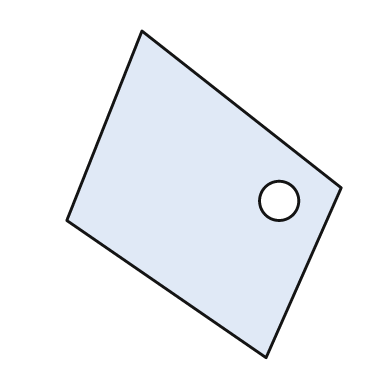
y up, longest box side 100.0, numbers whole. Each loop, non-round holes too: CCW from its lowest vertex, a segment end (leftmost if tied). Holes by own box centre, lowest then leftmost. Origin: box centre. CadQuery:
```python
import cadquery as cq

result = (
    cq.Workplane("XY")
    .moveTo(19.0, -50.0)
    .lineTo(42.0, 2.0)
    .lineTo(-19.0, 50.0)
    .lineTo(-42.0, -8.0)
    .close()
    .moveTo(23.0, -2.0)
    .circle(6.0)
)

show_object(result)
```